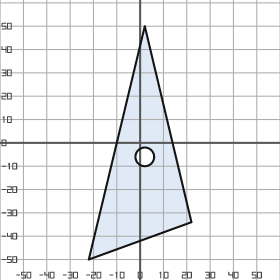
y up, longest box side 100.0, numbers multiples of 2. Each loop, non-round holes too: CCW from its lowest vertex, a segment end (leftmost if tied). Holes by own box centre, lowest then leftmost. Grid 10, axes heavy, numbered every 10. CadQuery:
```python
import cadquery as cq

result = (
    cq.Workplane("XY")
    .moveTo(-22.0, -50.0)
    .lineTo(22.0, -34.0)
    .lineTo(2.0, 50.0)
    .close()
    .moveTo(2.0, -6.0)
    .circle(4.0)
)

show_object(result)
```